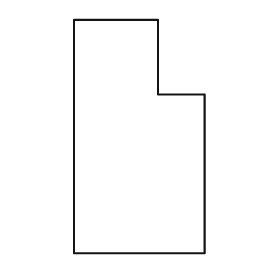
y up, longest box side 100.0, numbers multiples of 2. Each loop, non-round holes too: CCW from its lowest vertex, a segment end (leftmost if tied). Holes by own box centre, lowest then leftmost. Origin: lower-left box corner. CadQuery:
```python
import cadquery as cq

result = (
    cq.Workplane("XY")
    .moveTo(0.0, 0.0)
    .lineTo(56.0, 0.0)
    .lineTo(56.0, 68.0)
    .lineTo(36.0, 68.0)
    .lineTo(36.0, 100.0)
    .lineTo(0.0, 100.0)
    .close()
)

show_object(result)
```